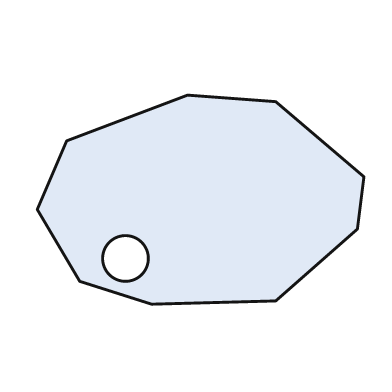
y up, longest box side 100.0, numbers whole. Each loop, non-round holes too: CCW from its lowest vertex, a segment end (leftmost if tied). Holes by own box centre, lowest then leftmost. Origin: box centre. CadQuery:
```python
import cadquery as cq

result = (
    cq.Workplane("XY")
    .moveTo(-15.0, -32.0)
    .lineTo(23.0, -31.0)
    .lineTo(48.0, -9.0)
    .lineTo(50.0, 7.0)
    .lineTo(23.0, 30.0)
    .lineTo(-4.0, 32.0)
    .lineTo(-41.0, 18.0)
    .lineTo(-50.0, -3.0)
    .lineTo(-37.0, -25.0)
    .close()
    .moveTo(-23.0, -18.0)
    .circle(7.0)
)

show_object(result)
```